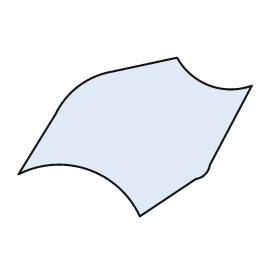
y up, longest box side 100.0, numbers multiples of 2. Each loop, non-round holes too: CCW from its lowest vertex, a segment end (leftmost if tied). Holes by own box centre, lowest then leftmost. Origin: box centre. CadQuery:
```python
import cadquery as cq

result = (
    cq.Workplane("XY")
    .moveTo(2.0, -34.0)
    .lineTo(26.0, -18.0)
    .threePointArc((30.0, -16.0), (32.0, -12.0))
    .lineTo(50.0, 22.0)
    .threePointArc((32.0, 22.0), (18.0, 34.0))
    .lineTo(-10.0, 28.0)
    .threePointArc((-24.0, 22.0), (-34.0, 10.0))
    .lineTo(-50.0, -16.0)
    .threePointArc((-20.0, -14.0), (2.0, -34.0))
    .close()
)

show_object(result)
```